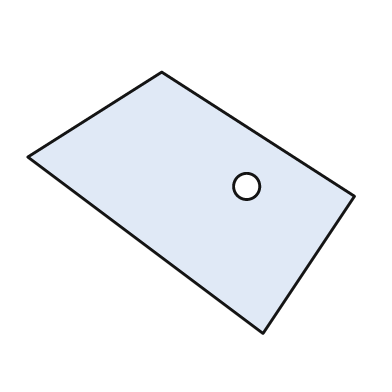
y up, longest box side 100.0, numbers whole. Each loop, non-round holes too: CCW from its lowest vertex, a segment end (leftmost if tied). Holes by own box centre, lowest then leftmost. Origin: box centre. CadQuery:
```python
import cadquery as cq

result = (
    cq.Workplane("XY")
    .moveTo(22.0, -40.0)
    .lineTo(50.0, 2.0)
    .lineTo(-9.0, 40.0)
    .lineTo(-50.0, 14.0)
    .close()
    .moveTo(17.0, 5.0)
    .circle(4.0)
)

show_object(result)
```